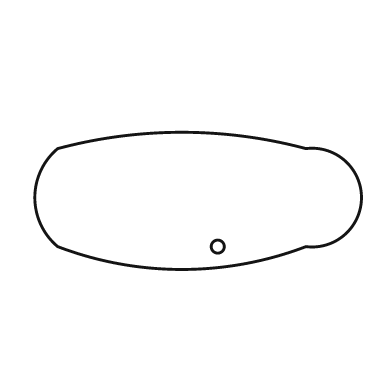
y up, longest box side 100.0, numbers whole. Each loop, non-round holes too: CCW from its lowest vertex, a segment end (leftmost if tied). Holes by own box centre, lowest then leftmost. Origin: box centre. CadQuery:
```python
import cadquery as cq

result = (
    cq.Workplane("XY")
    .moveTo(-43.0, -14.0)
    .threePointArc((-5.0, -21.0), (33.0, -14.0))
    .threePointArc((50.0, 1.0), (33.0, 16.0))
    .threePointArc((-5.0, 21.0), (-43.0, 16.0))
    .threePointArc((-50.0, 1.0), (-43.0, -14.0))
    .close()
    .moveTo(6.0, -14.0)
    .circle(2.0)
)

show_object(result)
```